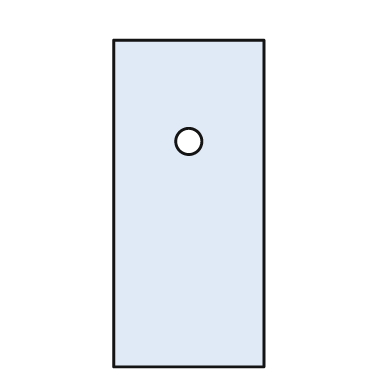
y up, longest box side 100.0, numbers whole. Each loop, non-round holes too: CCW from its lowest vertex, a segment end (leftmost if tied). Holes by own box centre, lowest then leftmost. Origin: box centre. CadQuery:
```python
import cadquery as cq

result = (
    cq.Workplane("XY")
    .moveTo(-23.0, -50.0)
    .lineTo(23.0, -50.0)
    .lineTo(23.0, 50.0)
    .lineTo(-23.0, 50.0)
    .close()
    .moveTo(0.0, 19.0)
    .circle(4.0)
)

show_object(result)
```